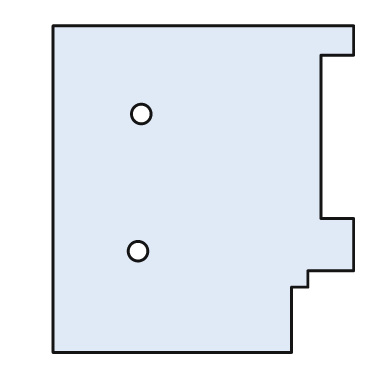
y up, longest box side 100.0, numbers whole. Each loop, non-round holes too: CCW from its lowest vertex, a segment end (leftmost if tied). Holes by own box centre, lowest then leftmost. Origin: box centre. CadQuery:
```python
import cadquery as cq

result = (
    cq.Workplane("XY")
    .moveTo(-46.0, -50.0)
    .lineTo(27.0, -50.0)
    .lineTo(27.0, -30.0)
    .lineTo(32.0, -30.0)
    .lineTo(32.0, -25.0)
    .lineTo(46.0, -25.0)
    .lineTo(46.0, -9.0)
    .lineTo(36.0, -9.0)
    .lineTo(36.0, 41.0)
    .lineTo(46.0, 41.0)
    .lineTo(46.0, 50.0)
    .lineTo(-46.0, 50.0)
    .close()
    .moveTo(-20.0, -19.0)
    .circle(3.0)
    .moveTo(-19.0, 23.0)
    .circle(3.0)
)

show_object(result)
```